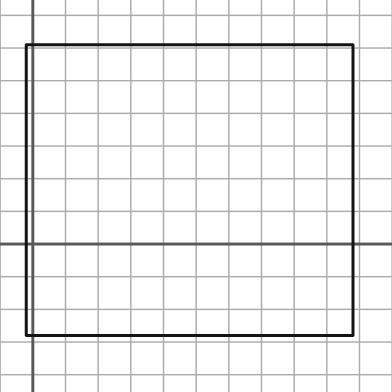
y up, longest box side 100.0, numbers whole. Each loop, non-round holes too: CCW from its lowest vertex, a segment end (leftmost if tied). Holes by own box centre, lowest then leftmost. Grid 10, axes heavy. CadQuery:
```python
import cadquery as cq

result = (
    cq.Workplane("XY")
    .moveTo(-2.0, -28.0)
    .lineTo(98.0, -28.0)
    .lineTo(98.0, 61.0)
    .lineTo(-2.0, 61.0)
    .close()
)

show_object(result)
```